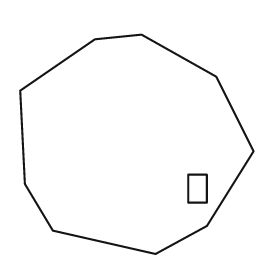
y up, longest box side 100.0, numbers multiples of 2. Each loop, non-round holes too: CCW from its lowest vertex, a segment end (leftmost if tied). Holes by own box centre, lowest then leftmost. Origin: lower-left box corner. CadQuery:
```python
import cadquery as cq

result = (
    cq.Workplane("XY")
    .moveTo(58.0, 0.0)
    .lineTo(80.0, 12.0)
    .lineTo(100.0, 44.0)
    .lineTo(84.0, 76.0)
    .lineTo(52.0, 94.0)
    .lineTo(32.0, 92.0)
    .lineTo(0.0, 70.0)
    .lineTo(2.0, 30.0)
    .lineTo(14.0, 10.0)
    .close()
    .moveTo(72.0, 22.0)
    .lineTo(80.0, 22.0)
    .lineTo(80.0, 34.0)
    .lineTo(72.0, 34.0)
    .close()
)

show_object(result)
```